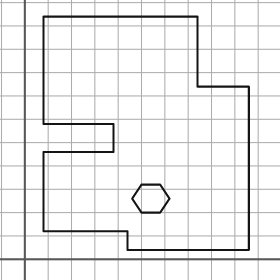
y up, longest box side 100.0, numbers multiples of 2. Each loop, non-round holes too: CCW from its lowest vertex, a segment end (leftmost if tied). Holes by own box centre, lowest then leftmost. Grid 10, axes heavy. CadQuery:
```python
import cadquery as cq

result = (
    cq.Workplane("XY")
    .moveTo(44.0, 4.0)
    .lineTo(96.0, 4.0)
    .lineTo(96.0, 74.0)
    .lineTo(74.0, 74.0)
    .lineTo(74.0, 104.0)
    .lineTo(8.0, 104.0)
    .lineTo(8.0, 58.0)
    .lineTo(38.0, 58.0)
    .lineTo(38.0, 46.0)
    .lineTo(8.0, 46.0)
    .lineTo(8.0, 12.0)
    .lineTo(44.0, 12.0)
    .close()
    .moveTo(50.0, 20.0)
    .lineTo(58.0, 20.0)
    .lineTo(62.0, 26.0)
    .lineTo(58.0, 32.0)
    .lineTo(50.0, 32.0)
    .lineTo(46.0, 26.0)
    .close()
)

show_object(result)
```